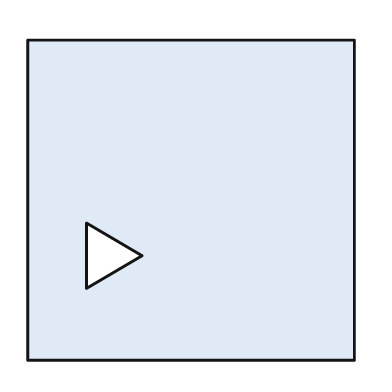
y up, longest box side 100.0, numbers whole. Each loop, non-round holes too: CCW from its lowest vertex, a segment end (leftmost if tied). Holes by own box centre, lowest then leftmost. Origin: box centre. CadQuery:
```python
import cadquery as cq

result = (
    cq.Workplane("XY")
    .moveTo(-50.0, -49.0)
    .lineTo(50.0, -49.0)
    .lineTo(50.0, 49.0)
    .lineTo(-50.0, 49.0)
    .close()
    .moveTo(-32.0, -27.0)
    .lineTo(-15.0, -17.0)
    .lineTo(-32.0, -7.0)
    .close()
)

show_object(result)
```